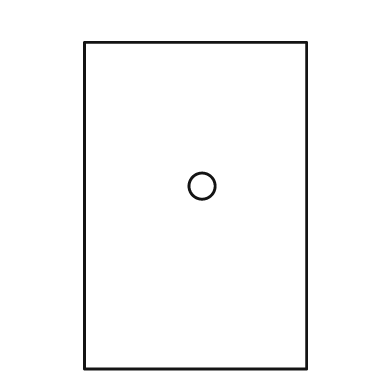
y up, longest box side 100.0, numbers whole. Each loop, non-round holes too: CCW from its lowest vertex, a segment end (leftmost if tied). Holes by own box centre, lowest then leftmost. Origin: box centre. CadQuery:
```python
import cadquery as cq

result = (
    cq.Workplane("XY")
    .moveTo(-34.0, -50.0)
    .lineTo(34.0, -50.0)
    .lineTo(34.0, 50.0)
    .lineTo(-34.0, 50.0)
    .close()
    .moveTo(2.0, 6.0)
    .circle(4.0)
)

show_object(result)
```